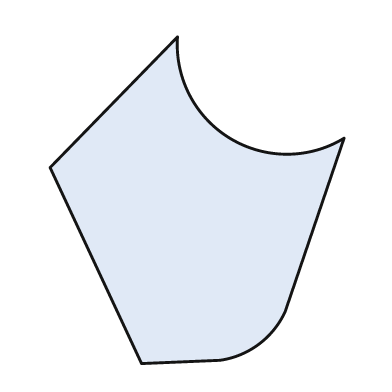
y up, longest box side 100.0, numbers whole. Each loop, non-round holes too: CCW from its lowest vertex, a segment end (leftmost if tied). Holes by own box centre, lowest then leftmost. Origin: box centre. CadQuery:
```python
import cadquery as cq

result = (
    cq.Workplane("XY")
    .moveTo(-17.0, -50.0)
    .lineTo(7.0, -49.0)
    .threePointArc((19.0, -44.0), (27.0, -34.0))
    .lineTo(45.0, 19.0)
    .threePointArc((10.0, 19.0), (-6.0, 50.0))
    .lineTo(-45.0, 10.0)
    .close()
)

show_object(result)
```